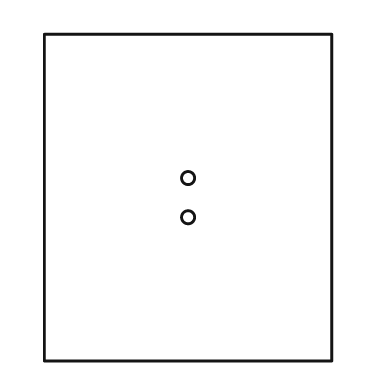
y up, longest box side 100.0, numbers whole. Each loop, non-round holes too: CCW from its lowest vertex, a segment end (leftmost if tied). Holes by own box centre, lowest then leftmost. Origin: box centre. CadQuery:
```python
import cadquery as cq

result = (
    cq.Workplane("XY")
    .moveTo(-44.0, -50.0)
    .lineTo(44.0, -50.0)
    .lineTo(44.0, 50.0)
    .lineTo(-44.0, 50.0)
    .close()
    .moveTo(0.0, -6.0)
    .circle(2.0)
    .moveTo(0.0, 6.0)
    .circle(2.0)
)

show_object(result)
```